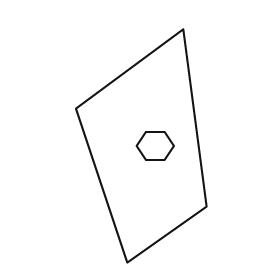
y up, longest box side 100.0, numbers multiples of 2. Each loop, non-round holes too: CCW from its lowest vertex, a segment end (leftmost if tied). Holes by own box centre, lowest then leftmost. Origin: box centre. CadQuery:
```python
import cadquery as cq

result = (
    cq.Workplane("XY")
    .moveTo(-6.0, -50.0)
    .lineTo(28.0, -26.0)
    .lineTo(18.0, 50.0)
    .lineTo(-28.0, 16.0)
    .close()
    .moveTo(2.0, -6.0)
    .lineTo(10.0, -6.0)
    .lineTo(14.0, 0.0)
    .lineTo(10.0, 6.0)
    .lineTo(2.0, 6.0)
    .lineTo(-2.0, 0.0)
    .close()
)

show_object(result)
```